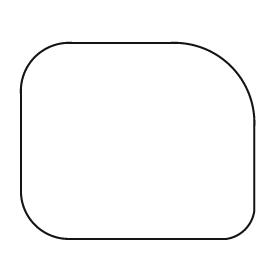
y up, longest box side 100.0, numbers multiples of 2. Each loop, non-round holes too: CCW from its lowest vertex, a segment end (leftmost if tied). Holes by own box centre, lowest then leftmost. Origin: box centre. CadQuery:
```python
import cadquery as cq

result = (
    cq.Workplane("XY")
    .moveTo(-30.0, -42.0)
    .lineTo(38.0, -42.0)
    .threePointArc((46.0, -38.0), (50.0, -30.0))
    .lineTo(50.0, 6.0)
    .threePointArc((40.0, 32.0), (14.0, 42.0))
    .lineTo(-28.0, 42.0)
    .threePointArc((-44.0, 36.0), (-50.0, 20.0))
    .lineTo(-50.0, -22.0)
    .threePointArc((-44.0, -36.0), (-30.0, -42.0))
    .close()
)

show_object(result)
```